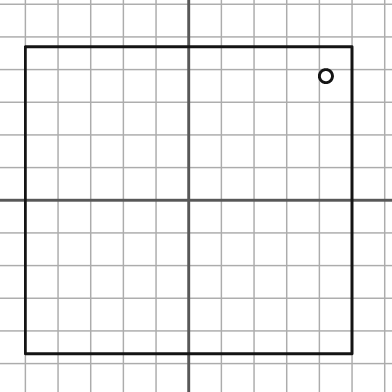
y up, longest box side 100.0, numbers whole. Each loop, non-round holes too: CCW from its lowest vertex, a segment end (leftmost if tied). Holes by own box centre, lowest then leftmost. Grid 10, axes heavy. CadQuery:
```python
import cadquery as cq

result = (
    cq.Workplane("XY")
    .moveTo(-50.0, -47.0)
    .lineTo(50.0, -47.0)
    .lineTo(50.0, 47.0)
    .lineTo(-50.0, 47.0)
    .close()
    .moveTo(42.0, 38.0)
    .circle(2.0)
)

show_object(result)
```